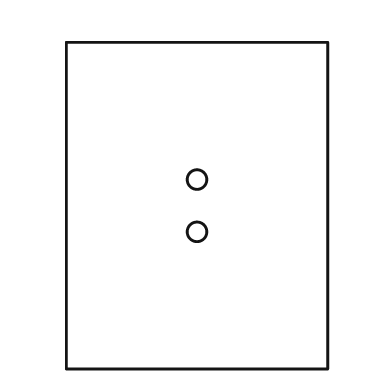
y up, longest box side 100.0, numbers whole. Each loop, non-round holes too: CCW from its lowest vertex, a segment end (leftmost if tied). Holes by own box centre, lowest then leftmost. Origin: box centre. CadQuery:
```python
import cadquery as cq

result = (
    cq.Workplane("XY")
    .moveTo(-40.0, -50.0)
    .lineTo(40.0, -50.0)
    .lineTo(40.0, 50.0)
    .lineTo(-40.0, 50.0)
    .close()
    .moveTo(0.0, -8.0)
    .circle(3.0)
    .moveTo(0.0, 8.0)
    .circle(3.0)
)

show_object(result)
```